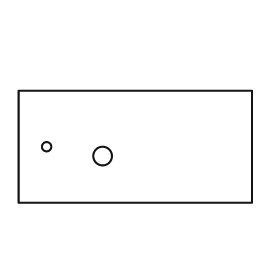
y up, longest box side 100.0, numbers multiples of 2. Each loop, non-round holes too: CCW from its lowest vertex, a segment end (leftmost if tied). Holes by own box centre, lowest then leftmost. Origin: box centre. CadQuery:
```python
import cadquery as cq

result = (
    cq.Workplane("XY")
    .moveTo(-50.0, -24.0)
    .lineTo(50.0, -24.0)
    .lineTo(50.0, 24.0)
    .lineTo(-50.0, 24.0)
    .close()
    .moveTo(-14.0, -4.0)
    .circle(4.0)
    .moveTo(-38.0, 0.0)
    .circle(2.0)
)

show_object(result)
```